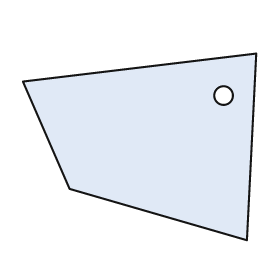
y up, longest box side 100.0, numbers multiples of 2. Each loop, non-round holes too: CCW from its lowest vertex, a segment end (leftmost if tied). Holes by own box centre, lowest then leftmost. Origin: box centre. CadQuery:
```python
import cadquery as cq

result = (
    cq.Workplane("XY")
    .moveTo(46.0, -40.0)
    .lineTo(50.0, 40.0)
    .lineTo(-50.0, 28.0)
    .lineTo(-30.0, -18.0)
    .close()
    .moveTo(36.0, 22.0)
    .circle(4.0)
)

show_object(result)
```